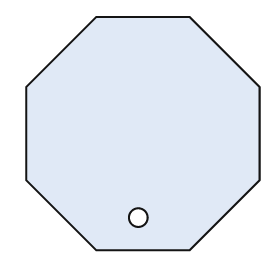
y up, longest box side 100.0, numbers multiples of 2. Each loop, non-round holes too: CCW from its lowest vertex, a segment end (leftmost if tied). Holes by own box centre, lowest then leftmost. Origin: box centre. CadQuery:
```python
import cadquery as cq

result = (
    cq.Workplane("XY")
    .moveTo(-20.0, -50.0)
    .lineTo(20.0, -50.0)
    .lineTo(50.0, -20.0)
    .lineTo(50.0, 20.0)
    .lineTo(20.0, 50.0)
    .lineTo(-20.0, 50.0)
    .lineTo(-50.0, 20.0)
    .lineTo(-50.0, -20.0)
    .close()
    .moveTo(-2.0, -36.0)
    .circle(4.0)
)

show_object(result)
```